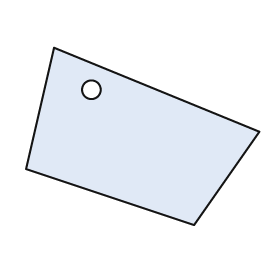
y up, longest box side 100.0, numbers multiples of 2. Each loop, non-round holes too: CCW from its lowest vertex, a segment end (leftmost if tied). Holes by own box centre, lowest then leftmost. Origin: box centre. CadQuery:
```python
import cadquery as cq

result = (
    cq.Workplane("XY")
    .moveTo(22.0, -38.0)
    .lineTo(50.0, 2.0)
    .lineTo(-38.0, 38.0)
    .lineTo(-50.0, -14.0)
    .close()
    .moveTo(-22.0, 20.0)
    .circle(4.0)
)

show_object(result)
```